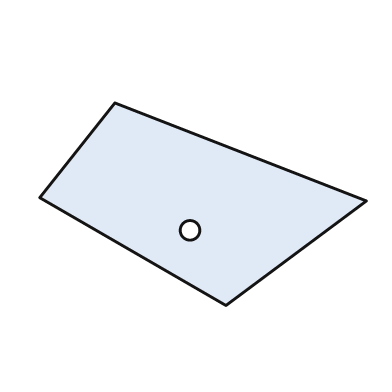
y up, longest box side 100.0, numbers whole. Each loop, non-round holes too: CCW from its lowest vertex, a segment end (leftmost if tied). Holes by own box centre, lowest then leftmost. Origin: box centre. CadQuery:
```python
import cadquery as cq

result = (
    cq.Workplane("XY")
    .moveTo(7.0, -31.0)
    .lineTo(50.0, 1.0)
    .lineTo(-27.0, 31.0)
    .lineTo(-50.0, 2.0)
    .close()
    .moveTo(-4.0, -8.0)
    .circle(3.0)
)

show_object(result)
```